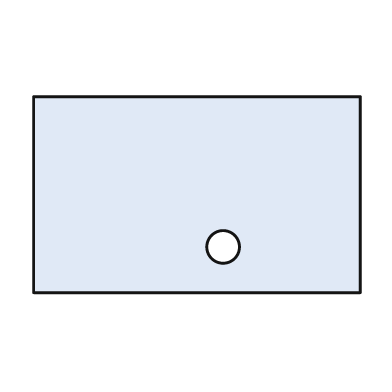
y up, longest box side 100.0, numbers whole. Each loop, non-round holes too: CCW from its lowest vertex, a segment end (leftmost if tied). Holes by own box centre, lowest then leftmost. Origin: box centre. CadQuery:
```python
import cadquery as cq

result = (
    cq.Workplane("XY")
    .moveTo(-50.0, -30.0)
    .lineTo(50.0, -30.0)
    .lineTo(50.0, 30.0)
    .lineTo(-50.0, 30.0)
    .close()
    .moveTo(8.0, -16.0)
    .circle(5.0)
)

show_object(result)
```